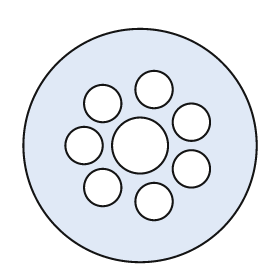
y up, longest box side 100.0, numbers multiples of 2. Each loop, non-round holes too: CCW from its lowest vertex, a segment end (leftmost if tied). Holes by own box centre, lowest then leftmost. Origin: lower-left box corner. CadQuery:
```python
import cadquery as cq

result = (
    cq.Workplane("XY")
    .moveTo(50.0, 50.0)
    .circle(50.0)
    .moveTo(56.0, 26.0)
    .circle(8.0)
    .moveTo(34.0, 32.0)
    .circle(8.0)
    .moveTo(72.0, 40.0)
    .circle(8.0)
    .moveTo(26.0, 50.0)
    .circle(8.0)
    .moveTo(50.0, 50.0)
    .circle(12.0)
    .moveTo(72.0, 60.0)
    .circle(8.0)
    .moveTo(34.0, 68.0)
    .circle(8.0)
    .moveTo(56.0, 74.0)
    .circle(8.0)
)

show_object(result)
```